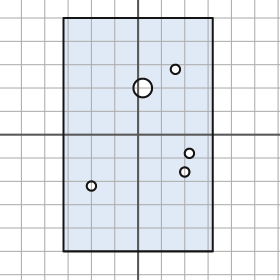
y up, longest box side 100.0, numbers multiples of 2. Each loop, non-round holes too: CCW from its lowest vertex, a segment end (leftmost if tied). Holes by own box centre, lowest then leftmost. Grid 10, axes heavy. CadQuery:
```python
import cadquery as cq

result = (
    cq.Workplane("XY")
    .moveTo(-32.0, -50.0)
    .lineTo(32.0, -50.0)
    .lineTo(32.0, 50.0)
    .lineTo(-32.0, 50.0)
    .close()
    .moveTo(-20.0, -22.0)
    .circle(2.0)
    .moveTo(20.0, -16.0)
    .circle(2.0)
    .moveTo(22.0, -8.0)
    .circle(2.0)
    .moveTo(2.0, 20.0)
    .circle(4.0)
    .moveTo(16.0, 28.0)
    .circle(2.0)
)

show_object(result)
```